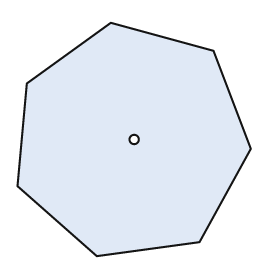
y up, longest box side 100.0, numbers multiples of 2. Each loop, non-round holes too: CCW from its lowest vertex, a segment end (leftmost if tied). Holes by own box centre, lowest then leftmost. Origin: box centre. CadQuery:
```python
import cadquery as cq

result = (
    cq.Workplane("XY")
    .moveTo(-16.0, -50.0)
    .lineTo(28.0, -44.0)
    .lineTo(50.0, -4.0)
    .lineTo(34.0, 38.0)
    .lineTo(-10.0, 50.0)
    .lineTo(-46.0, 24.0)
    .lineTo(-50.0, -20.0)
    .close()
    .moveTo(0.0, 0.0)
    .circle(2.0)
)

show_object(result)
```